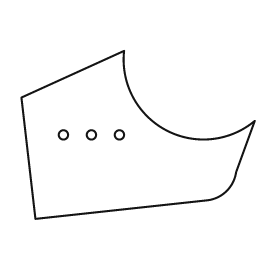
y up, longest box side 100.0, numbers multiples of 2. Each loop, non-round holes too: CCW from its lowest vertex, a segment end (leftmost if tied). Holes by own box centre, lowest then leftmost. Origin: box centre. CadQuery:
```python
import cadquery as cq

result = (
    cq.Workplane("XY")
    .moveTo(-44.0, -36.0)
    .lineTo(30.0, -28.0)
    .threePointArc((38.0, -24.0), (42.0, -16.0))
    .lineTo(50.0, 6.0)
    .threePointArc((12.0, 2.0), (-6.0, 36.0))
    .lineTo(-50.0, 16.0)
    .close()
    .moveTo(-32.0, 0.0)
    .circle(2.0)
    .moveTo(-20.0, 0.0)
    .circle(2.0)
    .moveTo(-8.0, 0.0)
    .circle(2.0)
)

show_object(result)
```